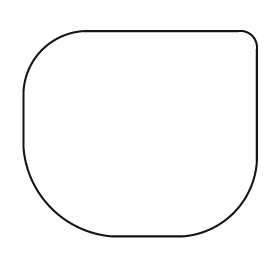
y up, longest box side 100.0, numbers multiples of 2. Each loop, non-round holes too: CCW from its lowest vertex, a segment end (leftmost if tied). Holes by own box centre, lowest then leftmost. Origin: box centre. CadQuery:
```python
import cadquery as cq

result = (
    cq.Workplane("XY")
    .moveTo(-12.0, -44.0)
    .lineTo(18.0, -44.0)
    .threePointArc((40.0, -34.0), (50.0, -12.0))
    .lineTo(50.0, 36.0)
    .threePointArc((48.0, 42.0), (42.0, 44.0))
    .lineTo(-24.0, 44.0)
    .threePointArc((-42.0, 36.0), (-50.0, 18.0))
    .lineTo(-50.0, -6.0)
    .threePointArc((-38.0, -32.0), (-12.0, -44.0))
    .close()
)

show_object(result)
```